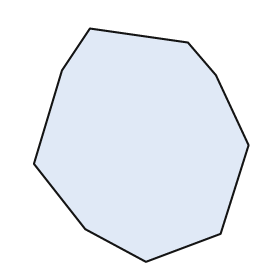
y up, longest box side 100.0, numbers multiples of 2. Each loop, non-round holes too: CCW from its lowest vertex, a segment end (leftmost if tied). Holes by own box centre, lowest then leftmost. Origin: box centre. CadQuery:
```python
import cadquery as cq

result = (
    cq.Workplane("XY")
    .moveTo(2.0, -50.0)
    .lineTo(34.0, -38.0)
    .lineTo(46.0, 0.0)
    .lineTo(32.0, 30.0)
    .lineTo(20.0, 44.0)
    .lineTo(-22.0, 50.0)
    .lineTo(-34.0, 32.0)
    .lineTo(-46.0, -8.0)
    .lineTo(-24.0, -36.0)
    .close()
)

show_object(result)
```